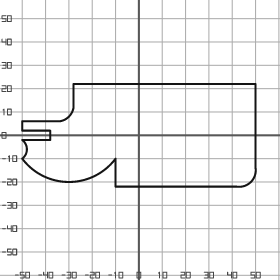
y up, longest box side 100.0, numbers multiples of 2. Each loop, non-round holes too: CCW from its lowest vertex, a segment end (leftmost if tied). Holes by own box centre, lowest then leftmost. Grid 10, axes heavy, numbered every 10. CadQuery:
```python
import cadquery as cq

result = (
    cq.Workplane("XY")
    .moveTo(-10.0, -22.0)
    .lineTo(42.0, -22.0)
    .threePointArc((48.0, -20.0), (50.0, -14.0))
    .lineTo(50.0, 22.0)
    .lineTo(-28.0, 22.0)
    .lineTo(-28.0, 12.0)
    .threePointArc((-30.0, 8.0), (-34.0, 6.0))
    .lineTo(-50.0, 6.0)
    .lineTo(-50.0, 2.0)
    .lineTo(-38.0, 2.0)
    .lineTo(-38.0, -2.0)
    .lineTo(-50.0, -2.0)
    .threePointArc((-48.0, -6.0), (-50.0, -10.0))
    .threePointArc((-30.0, -20.0), (-10.0, -10.0))
    .close()
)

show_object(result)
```